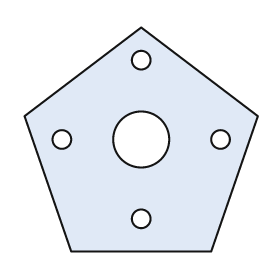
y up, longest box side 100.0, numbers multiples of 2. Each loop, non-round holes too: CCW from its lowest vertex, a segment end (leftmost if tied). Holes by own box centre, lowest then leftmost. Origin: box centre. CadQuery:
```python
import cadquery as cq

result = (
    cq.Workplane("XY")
    .moveTo(-30.0, -48.0)
    .lineTo(30.0, -48.0)
    .lineTo(50.0, 10.0)
    .lineTo(0.0, 48.0)
    .lineTo(-50.0, 10.0)
    .close()
    .moveTo(0.0, -34.0)
    .circle(4.0)
    .moveTo(-34.0, 0.0)
    .circle(4.0)
    .moveTo(0.0, 0.0)
    .circle(12.0)
    .moveTo(34.0, 0.0)
    .circle(4.0)
    .moveTo(0.0, 34.0)
    .circle(4.0)
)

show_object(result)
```